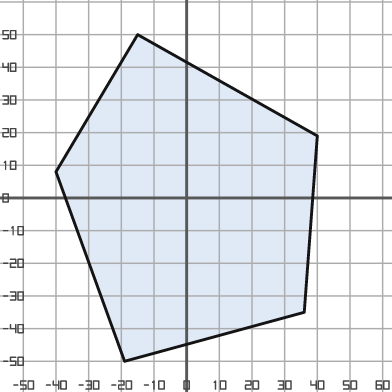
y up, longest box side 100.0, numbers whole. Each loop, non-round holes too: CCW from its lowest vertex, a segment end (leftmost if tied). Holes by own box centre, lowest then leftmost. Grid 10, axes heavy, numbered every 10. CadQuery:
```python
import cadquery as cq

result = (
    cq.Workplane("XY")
    .moveTo(-19.0, -50.0)
    .lineTo(36.0, -35.0)
    .lineTo(40.0, 19.0)
    .lineTo(-15.0, 50.0)
    .lineTo(-40.0, 8.0)
    .close()
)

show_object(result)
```